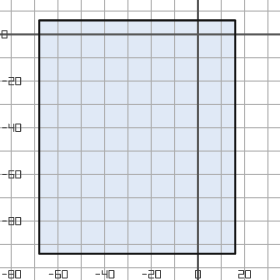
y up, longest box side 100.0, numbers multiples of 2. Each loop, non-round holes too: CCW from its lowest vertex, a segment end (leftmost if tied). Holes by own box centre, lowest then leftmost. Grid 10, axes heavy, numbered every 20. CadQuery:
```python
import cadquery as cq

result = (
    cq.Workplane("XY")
    .moveTo(-68.0, -94.0)
    .lineTo(16.0, -94.0)
    .lineTo(16.0, 6.0)
    .lineTo(-68.0, 6.0)
    .close()
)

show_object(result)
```